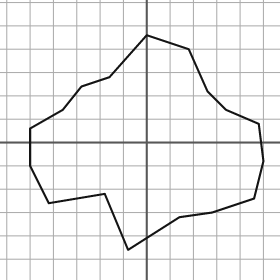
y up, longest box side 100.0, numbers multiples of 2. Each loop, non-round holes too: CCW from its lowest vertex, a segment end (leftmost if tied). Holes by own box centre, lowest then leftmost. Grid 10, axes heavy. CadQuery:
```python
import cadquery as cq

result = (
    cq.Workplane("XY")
    .moveTo(-8.0, -46.0)
    .lineTo(14.0, -32.0)
    .lineTo(28.0, -30.0)
    .lineTo(46.0, -24.0)
    .lineTo(50.0, -8.0)
    .lineTo(48.0, 8.0)
    .lineTo(34.0, 14.0)
    .lineTo(26.0, 22.0)
    .lineTo(18.0, 40.0)
    .lineTo(0.0, 46.0)
    .lineTo(-16.0, 28.0)
    .lineTo(-28.0, 24.0)
    .lineTo(-36.0, 14.0)
    .lineTo(-50.0, 6.0)
    .lineTo(-50.0, -10.0)
    .lineTo(-42.0, -26.0)
    .lineTo(-18.0, -22.0)
    .close()
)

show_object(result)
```